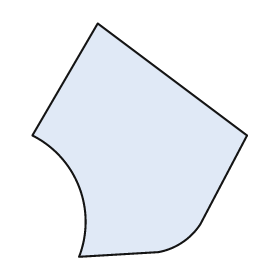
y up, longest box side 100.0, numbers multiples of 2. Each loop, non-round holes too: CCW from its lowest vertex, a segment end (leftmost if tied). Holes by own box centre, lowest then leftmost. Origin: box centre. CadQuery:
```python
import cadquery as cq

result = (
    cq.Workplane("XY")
    .moveTo(-26.0, -50.0)
    .lineTo(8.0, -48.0)
    .threePointArc((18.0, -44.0), (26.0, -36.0))
    .lineTo(46.0, 2.0)
    .lineTo(-18.0, 50.0)
    .lineTo(-46.0, 2.0)
    .threePointArc((-26.0, -20.0), (-26.0, -50.0))
    .close()
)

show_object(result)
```